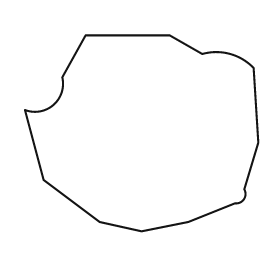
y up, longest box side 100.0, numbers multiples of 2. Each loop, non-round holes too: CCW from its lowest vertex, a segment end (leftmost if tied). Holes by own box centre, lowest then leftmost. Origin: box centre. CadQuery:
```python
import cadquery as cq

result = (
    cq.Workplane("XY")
    .moveTo(0.0, -42.0)
    .lineTo(20.0, -38.0)
    .lineTo(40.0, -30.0)
    .threePointArc((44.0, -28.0), (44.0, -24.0))
    .lineTo(50.0, -4.0)
    .lineTo(48.0, 28.0)
    .threePointArc((38.0, 34.0), (26.0, 34.0))
    .lineTo(12.0, 42.0)
    .lineTo(-24.0, 42.0)
    .lineTo(-34.0, 24.0)
    .threePointArc((-38.0, 12.0), (-50.0, 10.0))
    .lineTo(-42.0, -20.0)
    .lineTo(-18.0, -38.0)
    .close()
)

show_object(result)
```